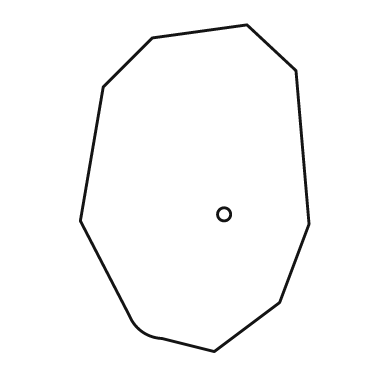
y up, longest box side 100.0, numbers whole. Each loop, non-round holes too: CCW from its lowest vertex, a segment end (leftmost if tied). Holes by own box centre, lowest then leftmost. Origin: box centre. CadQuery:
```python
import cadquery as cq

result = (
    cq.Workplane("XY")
    .moveTo(6.0, -50.0)
    .lineTo(26.0, -35.0)
    .lineTo(35.0, -11.0)
    .lineTo(31.0, 36.0)
    .lineTo(16.0, 50.0)
    .lineTo(-13.0, 46.0)
    .lineTo(-28.0, 31.0)
    .lineTo(-35.0, -10.0)
    .lineTo(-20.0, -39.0)
    .threePointArc((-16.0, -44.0), (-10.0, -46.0))
    .close()
    .moveTo(9.0, -8.0)
    .circle(2.0)
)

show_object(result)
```